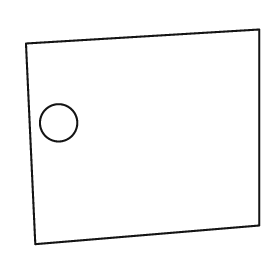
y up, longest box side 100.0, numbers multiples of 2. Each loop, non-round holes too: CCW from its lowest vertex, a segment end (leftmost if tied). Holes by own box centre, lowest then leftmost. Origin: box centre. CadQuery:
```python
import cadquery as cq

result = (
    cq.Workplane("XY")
    .moveTo(-46.0, -46.0)
    .lineTo(50.0, -38.0)
    .lineTo(50.0, 46.0)
    .lineTo(-50.0, 40.0)
    .close()
    .moveTo(-36.0, 6.0)
    .circle(8.0)
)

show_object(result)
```